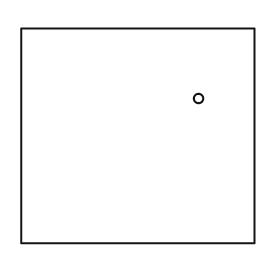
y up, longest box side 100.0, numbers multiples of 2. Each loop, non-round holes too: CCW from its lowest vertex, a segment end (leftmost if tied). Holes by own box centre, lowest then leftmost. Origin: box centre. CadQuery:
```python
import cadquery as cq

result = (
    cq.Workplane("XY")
    .moveTo(-50.0, -46.0)
    .lineTo(50.0, -46.0)
    .lineTo(50.0, 46.0)
    .lineTo(-50.0, 46.0)
    .close()
    .moveTo(26.0, 16.0)
    .circle(2.0)
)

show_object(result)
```